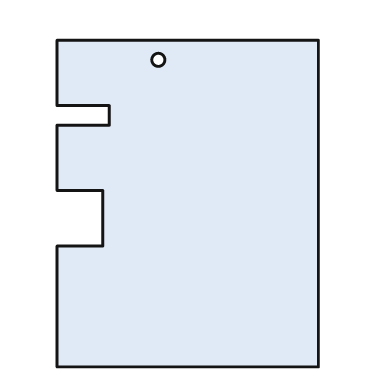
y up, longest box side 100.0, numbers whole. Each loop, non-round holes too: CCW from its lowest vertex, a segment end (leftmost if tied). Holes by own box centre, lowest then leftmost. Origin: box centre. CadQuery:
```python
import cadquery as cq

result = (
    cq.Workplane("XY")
    .moveTo(-40.0, -50.0)
    .lineTo(40.0, -50.0)
    .lineTo(40.0, 50.0)
    .lineTo(-40.0, 50.0)
    .lineTo(-40.0, 30.0)
    .lineTo(-24.0, 30.0)
    .lineTo(-24.0, 24.0)
    .lineTo(-40.0, 24.0)
    .lineTo(-40.0, 4.0)
    .lineTo(-26.0, 4.0)
    .lineTo(-26.0, -13.0)
    .lineTo(-40.0, -13.0)
    .close()
    .moveTo(-9.0, 44.0)
    .circle(2.0)
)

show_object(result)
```